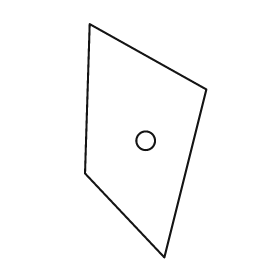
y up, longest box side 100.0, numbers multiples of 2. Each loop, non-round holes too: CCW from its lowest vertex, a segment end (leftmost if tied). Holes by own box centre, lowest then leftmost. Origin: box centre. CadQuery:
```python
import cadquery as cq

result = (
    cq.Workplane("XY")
    .moveTo(8.0, -50.0)
    .lineTo(26.0, 22.0)
    .lineTo(-24.0, 50.0)
    .lineTo(-26.0, -14.0)
    .close()
    .moveTo(0.0, 0.0)
    .circle(4.0)
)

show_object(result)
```